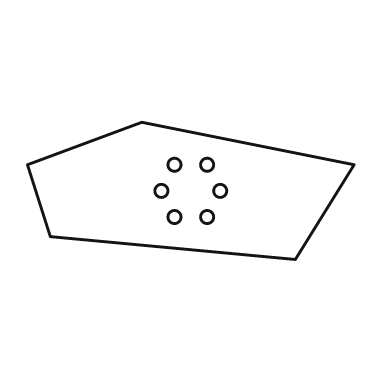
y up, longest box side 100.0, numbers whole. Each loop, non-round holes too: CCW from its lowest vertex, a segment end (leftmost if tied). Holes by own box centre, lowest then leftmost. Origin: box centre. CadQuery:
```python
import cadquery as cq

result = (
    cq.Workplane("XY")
    .moveTo(32.0, -21.0)
    .lineTo(50.0, 8.0)
    .lineTo(-15.0, 21.0)
    .lineTo(-50.0, 8.0)
    .lineTo(-43.0, -14.0)
    .close()
    .moveTo(-5.0, -8.0)
    .circle(2.0)
    .moveTo(5.0, -8.0)
    .circle(2.0)
    .moveTo(-9.0, 0.0)
    .circle(2.0)
    .moveTo(9.0, 0.0)
    .circle(2.0)
    .moveTo(-5.0, 8.0)
    .circle(2.0)
    .moveTo(5.0, 8.0)
    .circle(2.0)
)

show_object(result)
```